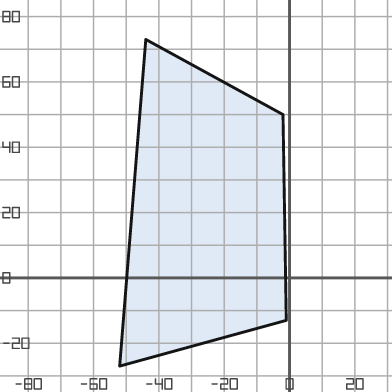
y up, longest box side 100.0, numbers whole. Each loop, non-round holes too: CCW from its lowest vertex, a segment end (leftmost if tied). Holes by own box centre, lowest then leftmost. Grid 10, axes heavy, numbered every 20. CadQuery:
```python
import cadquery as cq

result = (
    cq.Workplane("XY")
    .moveTo(-52.0, -27.0)
    .lineTo(-1.0, -13.0)
    .lineTo(-2.0, 50.0)
    .lineTo(-44.0, 73.0)
    .close()
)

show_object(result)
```